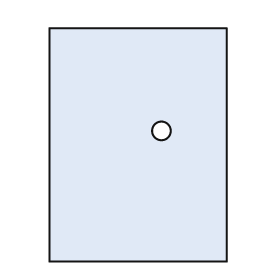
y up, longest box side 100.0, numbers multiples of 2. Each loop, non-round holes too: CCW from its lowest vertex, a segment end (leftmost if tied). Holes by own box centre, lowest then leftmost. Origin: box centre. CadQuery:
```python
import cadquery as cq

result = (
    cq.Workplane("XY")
    .moveTo(-38.0, -50.0)
    .lineTo(38.0, -50.0)
    .lineTo(38.0, 50.0)
    .lineTo(-38.0, 50.0)
    .close()
    .moveTo(10.0, 6.0)
    .circle(4.0)
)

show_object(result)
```